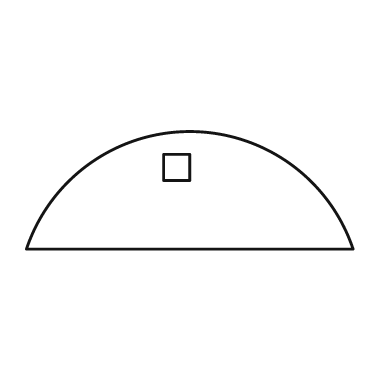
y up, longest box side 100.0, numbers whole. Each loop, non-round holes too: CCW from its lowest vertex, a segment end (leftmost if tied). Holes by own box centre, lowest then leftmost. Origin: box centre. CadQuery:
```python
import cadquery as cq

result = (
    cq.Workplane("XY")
    .moveTo(-50.0, -18.0)
    .lineTo(50.0, -18.0)
    .threePointArc((0.0, 18.0), (-50.0, -18.0))
    .close()
    .moveTo(-8.0, 3.0)
    .lineTo(0.0, 3.0)
    .lineTo(0.0, 11.0)
    .lineTo(-8.0, 11.0)
    .close()
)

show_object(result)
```